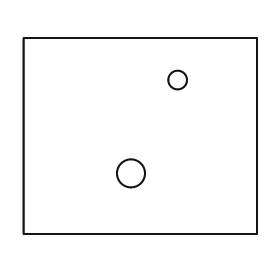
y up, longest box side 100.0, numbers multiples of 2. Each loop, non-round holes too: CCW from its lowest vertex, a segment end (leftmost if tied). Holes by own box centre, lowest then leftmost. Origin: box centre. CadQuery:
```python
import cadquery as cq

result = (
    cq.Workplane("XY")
    .moveTo(-50.0, -42.0)
    .lineTo(50.0, -42.0)
    .lineTo(50.0, 42.0)
    .lineTo(-50.0, 42.0)
    .close()
    .moveTo(-4.0, -16.0)
    .circle(6.0)
    .moveTo(16.0, 24.0)
    .circle(4.0)
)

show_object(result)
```